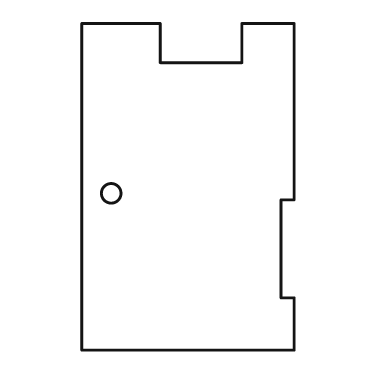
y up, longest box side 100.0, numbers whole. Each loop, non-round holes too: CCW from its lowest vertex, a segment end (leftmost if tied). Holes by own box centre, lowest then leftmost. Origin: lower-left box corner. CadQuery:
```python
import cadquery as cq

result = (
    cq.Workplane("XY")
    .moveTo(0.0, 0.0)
    .lineTo(65.0, 0.0)
    .lineTo(65.0, 16.0)
    .lineTo(61.0, 16.0)
    .lineTo(61.0, 46.0)
    .lineTo(65.0, 46.0)
    .lineTo(65.0, 100.0)
    .lineTo(49.0, 100.0)
    .lineTo(49.0, 88.0)
    .lineTo(24.0, 88.0)
    .lineTo(24.0, 100.0)
    .lineTo(0.0, 100.0)
    .close()
    .moveTo(9.0, 48.0)
    .circle(3.0)
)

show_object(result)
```